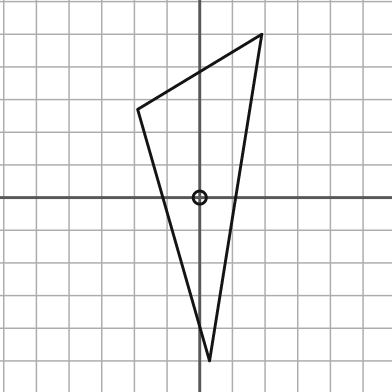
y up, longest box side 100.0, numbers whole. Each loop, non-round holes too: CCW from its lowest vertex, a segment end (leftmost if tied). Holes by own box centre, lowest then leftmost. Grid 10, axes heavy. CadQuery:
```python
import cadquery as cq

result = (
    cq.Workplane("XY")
    .moveTo(3.0, -50.0)
    .lineTo(19.0, 50.0)
    .lineTo(-19.0, 27.0)
    .close()
    .moveTo(0.0, 0.0)
    .circle(2.0)
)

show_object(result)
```